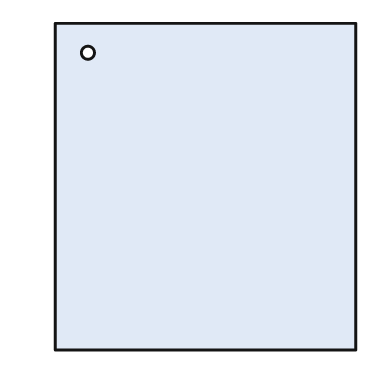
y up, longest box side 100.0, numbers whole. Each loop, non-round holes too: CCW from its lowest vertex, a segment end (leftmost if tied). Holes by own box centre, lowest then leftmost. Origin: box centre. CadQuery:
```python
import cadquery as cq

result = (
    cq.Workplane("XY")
    .moveTo(-46.0, -50.0)
    .lineTo(46.0, -50.0)
    .lineTo(46.0, 50.0)
    .lineTo(-46.0, 50.0)
    .close()
    .moveTo(-36.0, 41.0)
    .circle(2.0)
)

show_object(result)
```